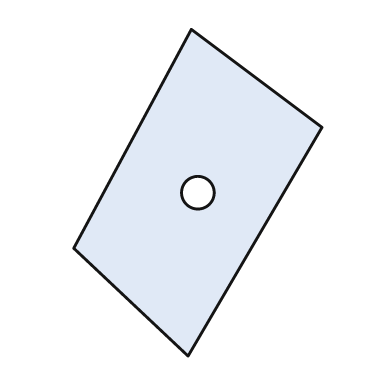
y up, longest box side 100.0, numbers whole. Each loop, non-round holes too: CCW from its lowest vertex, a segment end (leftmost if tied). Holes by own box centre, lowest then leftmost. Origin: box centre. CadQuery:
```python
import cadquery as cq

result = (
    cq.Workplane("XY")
    .moveTo(-3.0, -50.0)
    .lineTo(38.0, 20.0)
    .lineTo(-2.0, 50.0)
    .lineTo(-38.0, -17.0)
    .close()
    .moveTo(0.0, 0.0)
    .circle(5.0)
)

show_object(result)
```